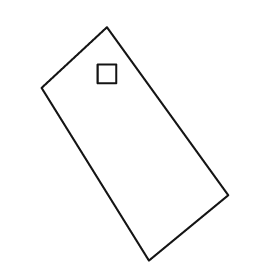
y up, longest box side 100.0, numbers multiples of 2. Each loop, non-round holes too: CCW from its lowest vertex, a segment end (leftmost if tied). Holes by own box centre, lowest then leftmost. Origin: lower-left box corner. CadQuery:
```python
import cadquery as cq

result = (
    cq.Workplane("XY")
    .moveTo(46.0, 0.0)
    .lineTo(80.0, 28.0)
    .lineTo(28.0, 100.0)
    .lineTo(0.0, 74.0)
    .close()
    .moveTo(24.0, 76.0)
    .lineTo(32.0, 76.0)
    .lineTo(32.0, 84.0)
    .lineTo(24.0, 84.0)
    .close()
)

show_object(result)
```